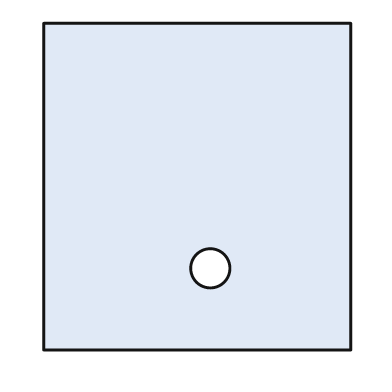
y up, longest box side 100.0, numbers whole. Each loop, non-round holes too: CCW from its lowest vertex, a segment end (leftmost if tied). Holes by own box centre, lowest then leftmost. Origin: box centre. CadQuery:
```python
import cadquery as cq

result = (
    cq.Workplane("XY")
    .moveTo(-47.0, -50.0)
    .lineTo(47.0, -50.0)
    .lineTo(47.0, 50.0)
    .lineTo(-47.0, 50.0)
    .close()
    .moveTo(4.0, -25.0)
    .circle(6.0)
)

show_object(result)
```